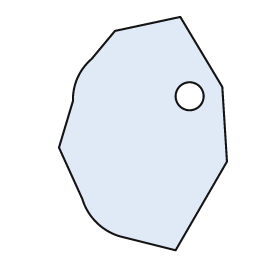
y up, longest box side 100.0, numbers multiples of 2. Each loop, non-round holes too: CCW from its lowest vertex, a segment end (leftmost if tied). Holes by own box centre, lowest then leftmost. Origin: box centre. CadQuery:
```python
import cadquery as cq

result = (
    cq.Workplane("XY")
    .moveTo(14.0, -50.0)
    .lineTo(36.0, -12.0)
    .lineTo(34.0, 20.0)
    .lineTo(16.0, 50.0)
    .lineTo(-12.0, 44.0)
    .lineTo(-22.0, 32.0)
    .threePointArc((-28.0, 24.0), (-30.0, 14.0))
    .lineTo(-36.0, -6.0)
    .lineTo(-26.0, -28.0)
    .threePointArc((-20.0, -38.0), (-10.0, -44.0))
    .close()
    .moveTo(20.0, 16.0)
    .circle(6.0)
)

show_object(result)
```